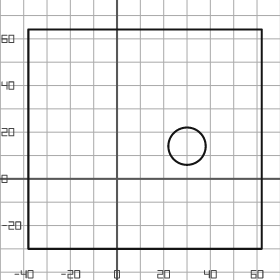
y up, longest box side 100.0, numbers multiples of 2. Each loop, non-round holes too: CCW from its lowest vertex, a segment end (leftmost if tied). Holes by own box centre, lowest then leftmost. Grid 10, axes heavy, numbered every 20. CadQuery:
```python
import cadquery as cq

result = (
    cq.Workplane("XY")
    .moveTo(-38.0, -30.0)
    .lineTo(62.0, -30.0)
    .lineTo(62.0, 64.0)
    .lineTo(-38.0, 64.0)
    .close()
    .moveTo(30.0, 14.0)
    .circle(8.0)
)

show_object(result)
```